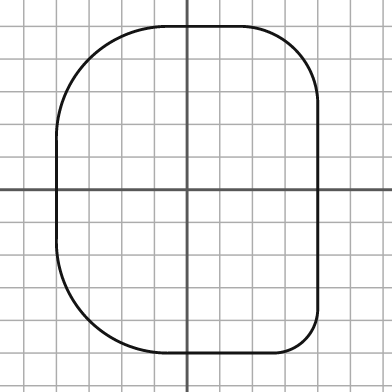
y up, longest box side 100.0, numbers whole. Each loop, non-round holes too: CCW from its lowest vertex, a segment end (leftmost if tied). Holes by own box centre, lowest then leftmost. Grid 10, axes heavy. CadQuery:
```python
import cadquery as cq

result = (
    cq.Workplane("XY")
    .moveTo(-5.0, -50.0)
    .lineTo(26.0, -50.0)
    .threePointArc((36.0, -46.0), (40.0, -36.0))
    .lineTo(40.0, 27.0)
    .threePointArc((33.0, 43.0), (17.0, 50.0))
    .lineTo(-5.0, 50.0)
    .threePointArc((-30.0, 40.0), (-40.0, 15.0))
    .lineTo(-40.0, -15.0)
    .threePointArc((-30.0, -40.0), (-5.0, -50.0))
    .close()
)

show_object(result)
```